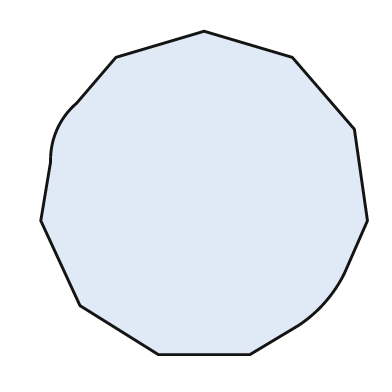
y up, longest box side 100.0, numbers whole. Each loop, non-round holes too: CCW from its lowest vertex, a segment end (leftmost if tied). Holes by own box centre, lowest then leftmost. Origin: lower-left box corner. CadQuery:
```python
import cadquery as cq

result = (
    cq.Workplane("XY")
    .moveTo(36.0, 0.0)
    .lineTo(64.0, 0.0)
    .lineTo(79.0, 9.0)
    .threePointArc((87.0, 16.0), (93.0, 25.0))
    .lineTo(100.0, 41.0)
    .lineTo(96.0, 69.0)
    .lineTo(77.0, 91.0)
    .lineTo(50.0, 99.0)
    .lineTo(23.0, 91.0)
    .lineTo(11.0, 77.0)
    .threePointArc((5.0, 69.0), (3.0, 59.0))
    .lineTo(0.0, 41.0)
    .lineTo(12.0, 15.0)
    .close()
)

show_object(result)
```